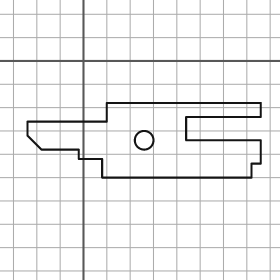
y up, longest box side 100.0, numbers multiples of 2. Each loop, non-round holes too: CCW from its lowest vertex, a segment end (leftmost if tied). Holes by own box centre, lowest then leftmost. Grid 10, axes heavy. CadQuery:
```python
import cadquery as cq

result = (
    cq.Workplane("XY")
    .moveTo(8.0, -50.0)
    .lineTo(72.0, -50.0)
    .lineTo(72.0, -44.0)
    .lineTo(76.0, -44.0)
    .lineTo(76.0, -34.0)
    .lineTo(44.0, -34.0)
    .lineTo(44.0, -24.0)
    .lineTo(76.0, -24.0)
    .lineTo(76.0, -18.0)
    .lineTo(10.0, -18.0)
    .lineTo(10.0, -26.0)
    .lineTo(-24.0, -26.0)
    .lineTo(-24.0, -32.0)
    .lineTo(-18.0, -38.0)
    .lineTo(-2.0, -38.0)
    .lineTo(-2.0, -42.0)
    .lineTo(8.0, -42.0)
    .close()
    .moveTo(26.0, -34.0)
    .circle(4.0)
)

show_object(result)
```